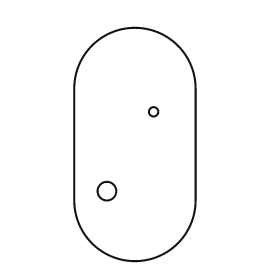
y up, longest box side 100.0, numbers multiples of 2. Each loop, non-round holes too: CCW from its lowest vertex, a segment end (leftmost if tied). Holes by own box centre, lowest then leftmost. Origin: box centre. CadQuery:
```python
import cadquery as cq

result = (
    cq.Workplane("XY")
    .moveTo(-26.0, -24.0)
    .threePointArc((0.0, -50.0), (26.0, -24.0))
    .lineTo(26.0, 24.0)
    .threePointArc((0.0, 50.0), (-26.0, 24.0))
    .close()
    .moveTo(-12.0, -20.0)
    .circle(4.0)
    .moveTo(8.0, 14.0)
    .circle(2.0)
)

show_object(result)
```